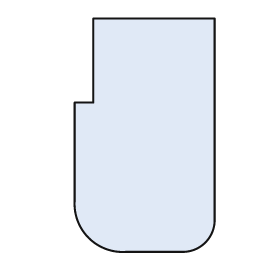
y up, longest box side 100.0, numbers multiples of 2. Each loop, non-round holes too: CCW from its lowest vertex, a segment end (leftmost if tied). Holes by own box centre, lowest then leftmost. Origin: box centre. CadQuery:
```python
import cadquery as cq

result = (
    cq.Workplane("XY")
    .moveTo(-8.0, -50.0)
    .lineTo(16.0, -50.0)
    .threePointArc((26.0, -46.0), (30.0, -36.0))
    .lineTo(30.0, 50.0)
    .lineTo(-22.0, 50.0)
    .lineTo(-22.0, 14.0)
    .lineTo(-30.0, 14.0)
    .lineTo(-30.0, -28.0)
    .threePointArc((-24.0, -44.0), (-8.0, -50.0))
    .close()
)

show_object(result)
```